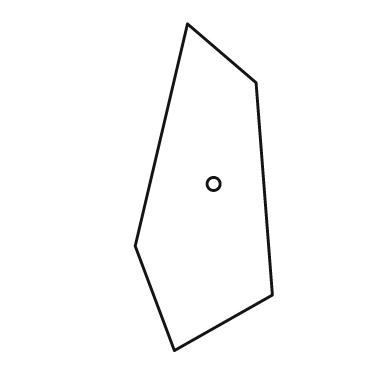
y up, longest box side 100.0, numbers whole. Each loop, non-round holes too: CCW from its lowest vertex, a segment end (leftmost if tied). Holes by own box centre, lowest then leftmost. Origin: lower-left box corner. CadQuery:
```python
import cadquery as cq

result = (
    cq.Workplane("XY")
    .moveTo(12.0, 0.0)
    .lineTo(42.0, 17.0)
    .lineTo(37.0, 82.0)
    .lineTo(16.0, 100.0)
    .lineTo(0.0, 32.0)
    .close()
    .moveTo(24.0, 51.0)
    .circle(2.0)
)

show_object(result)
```